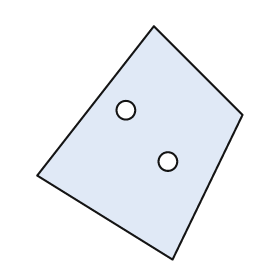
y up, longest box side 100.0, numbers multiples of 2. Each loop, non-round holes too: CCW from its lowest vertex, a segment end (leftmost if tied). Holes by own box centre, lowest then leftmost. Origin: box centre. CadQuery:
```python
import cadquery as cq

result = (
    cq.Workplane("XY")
    .moveTo(14.0, -50.0)
    .lineTo(44.0, 12.0)
    .lineTo(6.0, 50.0)
    .lineTo(-44.0, -14.0)
    .close()
    .moveTo(12.0, -8.0)
    .circle(4.0)
    .moveTo(-6.0, 14.0)
    .circle(4.0)
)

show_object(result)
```